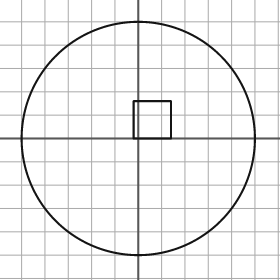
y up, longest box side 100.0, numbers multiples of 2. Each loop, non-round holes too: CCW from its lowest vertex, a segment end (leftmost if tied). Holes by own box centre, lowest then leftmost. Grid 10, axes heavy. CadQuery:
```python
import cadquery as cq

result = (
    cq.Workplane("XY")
    .moveTo(0.0, 0.0)
    .circle(50.0)
    .moveTo(-2.0, 0.0)
    .lineTo(14.0, 0.0)
    .lineTo(14.0, 16.0)
    .lineTo(-2.0, 16.0)
    .close()
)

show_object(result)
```